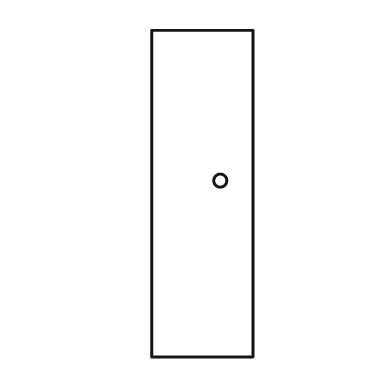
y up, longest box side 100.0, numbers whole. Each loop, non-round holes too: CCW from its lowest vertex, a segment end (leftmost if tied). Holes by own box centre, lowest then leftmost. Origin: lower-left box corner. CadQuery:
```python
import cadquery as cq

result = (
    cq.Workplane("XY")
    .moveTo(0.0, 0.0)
    .lineTo(31.0, 0.0)
    .lineTo(31.0, 100.0)
    .lineTo(0.0, 100.0)
    .close()
    .moveTo(21.0, 54.0)
    .circle(2.0)
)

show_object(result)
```